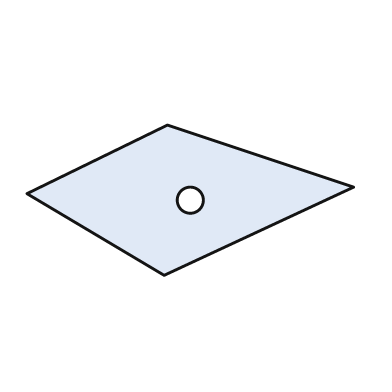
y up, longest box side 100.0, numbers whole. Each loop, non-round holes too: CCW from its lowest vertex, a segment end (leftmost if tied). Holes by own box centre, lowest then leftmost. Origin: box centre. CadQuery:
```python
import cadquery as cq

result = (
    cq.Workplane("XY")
    .moveTo(-8.0, -23.0)
    .lineTo(50.0, 4.0)
    .lineTo(-7.0, 23.0)
    .lineTo(-50.0, 2.0)
    .close()
    .moveTo(0.0, 0.0)
    .circle(4.0)
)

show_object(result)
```